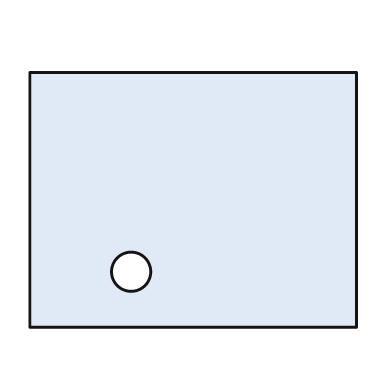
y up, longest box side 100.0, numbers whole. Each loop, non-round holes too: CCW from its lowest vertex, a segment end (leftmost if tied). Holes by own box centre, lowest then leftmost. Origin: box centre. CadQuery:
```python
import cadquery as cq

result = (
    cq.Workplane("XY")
    .moveTo(-50.0, -39.0)
    .lineTo(50.0, -39.0)
    .lineTo(50.0, 39.0)
    .lineTo(-50.0, 39.0)
    .close()
    .moveTo(-19.0, -22.0)
    .circle(6.0)
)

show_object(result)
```